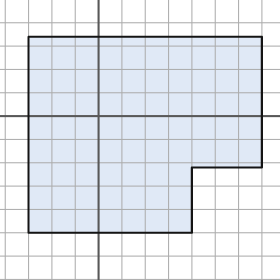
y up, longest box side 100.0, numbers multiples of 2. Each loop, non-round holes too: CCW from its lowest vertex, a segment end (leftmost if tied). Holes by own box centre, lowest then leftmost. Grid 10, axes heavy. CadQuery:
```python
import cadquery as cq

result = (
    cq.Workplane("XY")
    .moveTo(-30.0, -50.0)
    .lineTo(40.0, -50.0)
    .lineTo(40.0, -22.0)
    .lineTo(70.0, -22.0)
    .lineTo(70.0, 34.0)
    .lineTo(-30.0, 34.0)
    .close()
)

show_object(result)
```